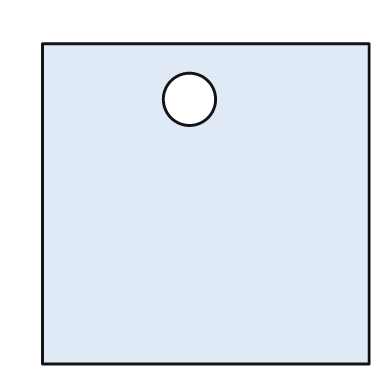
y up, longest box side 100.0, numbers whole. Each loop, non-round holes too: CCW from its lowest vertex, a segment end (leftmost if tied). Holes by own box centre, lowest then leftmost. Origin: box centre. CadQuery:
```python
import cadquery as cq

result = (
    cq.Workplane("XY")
    .moveTo(-50.0, -49.0)
    .lineTo(50.0, -49.0)
    .lineTo(50.0, 49.0)
    .lineTo(-50.0, 49.0)
    .close()
    .moveTo(-5.0, 32.0)
    .circle(8.0)
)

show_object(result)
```